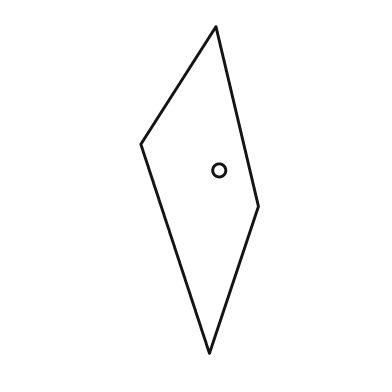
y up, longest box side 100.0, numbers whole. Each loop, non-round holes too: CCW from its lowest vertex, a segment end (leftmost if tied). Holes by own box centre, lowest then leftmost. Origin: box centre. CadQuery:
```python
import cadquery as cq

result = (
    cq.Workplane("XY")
    .moveTo(3.0, -50.0)
    .lineTo(18.0, -5.0)
    .lineTo(5.0, 50.0)
    .lineTo(-18.0, 14.0)
    .close()
    .moveTo(6.0, 6.0)
    .circle(2.0)
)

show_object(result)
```